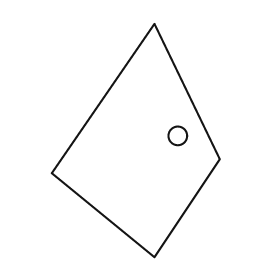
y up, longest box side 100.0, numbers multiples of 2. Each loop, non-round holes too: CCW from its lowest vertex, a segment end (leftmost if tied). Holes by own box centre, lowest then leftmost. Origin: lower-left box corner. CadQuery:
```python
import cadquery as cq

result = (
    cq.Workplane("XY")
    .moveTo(44.0, 0.0)
    .lineTo(72.0, 42.0)
    .lineTo(44.0, 100.0)
    .lineTo(0.0, 36.0)
    .close()
    .moveTo(54.0, 52.0)
    .circle(4.0)
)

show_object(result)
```